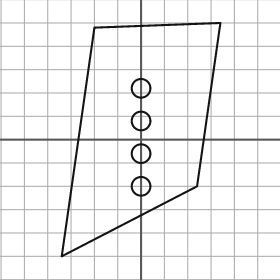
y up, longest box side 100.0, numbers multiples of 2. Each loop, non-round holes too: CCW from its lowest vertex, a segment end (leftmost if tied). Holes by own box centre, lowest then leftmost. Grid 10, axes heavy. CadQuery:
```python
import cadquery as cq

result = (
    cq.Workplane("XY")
    .moveTo(-34.0, -50.0)
    .lineTo(24.0, -20.0)
    .lineTo(34.0, 50.0)
    .lineTo(-20.0, 48.0)
    .close()
    .moveTo(0.0, -20.0)
    .circle(4.0)
    .moveTo(0.0, -6.0)
    .circle(4.0)
    .moveTo(0.0, 8.0)
    .circle(4.0)
    .moveTo(0.0, 22.0)
    .circle(4.0)
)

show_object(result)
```